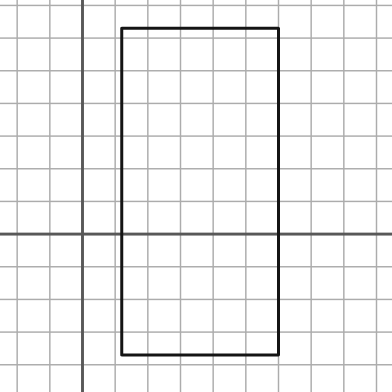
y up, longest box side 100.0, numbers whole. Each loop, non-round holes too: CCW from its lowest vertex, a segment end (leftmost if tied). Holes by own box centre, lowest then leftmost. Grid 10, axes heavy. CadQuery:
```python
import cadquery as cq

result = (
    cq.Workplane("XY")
    .moveTo(12.0, -37.0)
    .lineTo(60.0, -37.0)
    .lineTo(60.0, 63.0)
    .lineTo(12.0, 63.0)
    .close()
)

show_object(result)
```